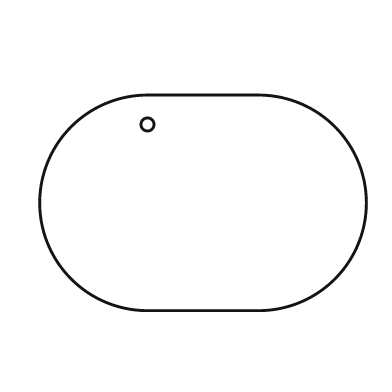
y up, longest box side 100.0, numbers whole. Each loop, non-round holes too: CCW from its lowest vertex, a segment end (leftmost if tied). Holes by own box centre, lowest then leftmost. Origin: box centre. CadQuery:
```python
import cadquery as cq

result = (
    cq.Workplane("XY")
    .moveTo(-17.0, -33.0)
    .lineTo(17.0, -33.0)
    .threePointArc((50.0, 0.0), (17.0, 33.0))
    .lineTo(-17.0, 33.0)
    .threePointArc((-50.0, 0.0), (-17.0, -33.0))
    .close()
    .moveTo(-17.0, 24.0)
    .circle(2.0)
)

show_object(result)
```